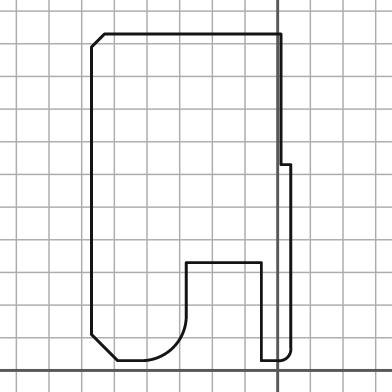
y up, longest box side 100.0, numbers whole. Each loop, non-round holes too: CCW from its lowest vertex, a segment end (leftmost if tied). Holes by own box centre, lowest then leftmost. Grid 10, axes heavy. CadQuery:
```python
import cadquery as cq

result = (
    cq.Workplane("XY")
    .moveTo(-49.0, 3.0)
    .lineTo(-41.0, 3.0)
    .threePointArc((-32.0, 7.0), (-28.0, 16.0))
    .lineTo(-28.0, 33.0)
    .lineTo(-5.0, 33.0)
    .lineTo(-5.0, 3.0)
    .lineTo(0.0, 3.0)
    .threePointArc((3.0, 4.0), (4.0, 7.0))
    .lineTo(4.0, 63.0)
    .lineTo(1.0, 63.0)
    .lineTo(1.0, 103.0)
    .lineTo(-53.0, 103.0)
    .lineTo(-57.0, 99.0)
    .lineTo(-57.0, 11.0)
    .close()
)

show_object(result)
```